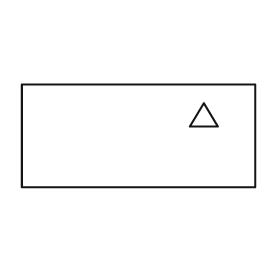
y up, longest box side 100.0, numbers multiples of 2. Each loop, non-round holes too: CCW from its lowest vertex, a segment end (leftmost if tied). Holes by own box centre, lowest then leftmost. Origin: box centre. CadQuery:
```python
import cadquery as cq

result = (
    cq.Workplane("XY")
    .moveTo(-50.0, -22.0)
    .lineTo(50.0, -22.0)
    .lineTo(50.0, 22.0)
    .lineTo(-50.0, 22.0)
    .close()
    .moveTo(22.0, 4.0)
    .lineTo(34.0, 4.0)
    .lineTo(28.0, 14.0)
    .close()
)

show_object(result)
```